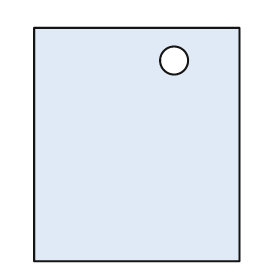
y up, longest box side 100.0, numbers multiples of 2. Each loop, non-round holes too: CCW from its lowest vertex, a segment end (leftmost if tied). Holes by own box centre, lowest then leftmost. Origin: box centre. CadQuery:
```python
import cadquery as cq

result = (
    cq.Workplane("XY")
    .moveTo(-44.0, -50.0)
    .lineTo(44.0, -50.0)
    .lineTo(44.0, 50.0)
    .lineTo(-44.0, 50.0)
    .close()
    .moveTo(16.0, 36.0)
    .circle(6.0)
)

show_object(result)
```